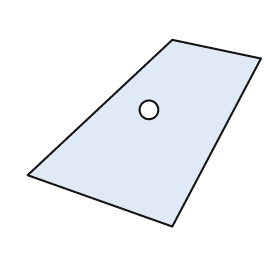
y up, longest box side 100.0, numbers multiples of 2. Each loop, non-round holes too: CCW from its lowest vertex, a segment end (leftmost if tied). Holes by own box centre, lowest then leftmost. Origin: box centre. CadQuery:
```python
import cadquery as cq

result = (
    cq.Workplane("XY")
    .moveTo(12.0, -40.0)
    .lineTo(50.0, 32.0)
    .lineTo(12.0, 40.0)
    .lineTo(-50.0, -18.0)
    .close()
    .moveTo(2.0, 10.0)
    .circle(4.0)
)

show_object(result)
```